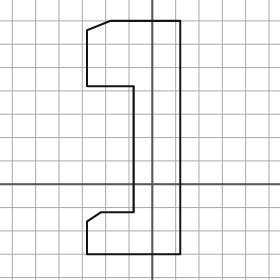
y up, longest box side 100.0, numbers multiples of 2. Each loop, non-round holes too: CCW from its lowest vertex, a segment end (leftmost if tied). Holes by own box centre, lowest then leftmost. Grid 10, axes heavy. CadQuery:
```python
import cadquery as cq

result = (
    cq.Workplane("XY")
    .moveTo(-28.0, -30.0)
    .lineTo(12.0, -30.0)
    .lineTo(12.0, 70.0)
    .lineTo(-18.0, 70.0)
    .lineTo(-28.0, 66.0)
    .lineTo(-28.0, 42.0)
    .lineTo(-8.0, 42.0)
    .lineTo(-8.0, -12.0)
    .lineTo(-22.0, -12.0)
    .lineTo(-28.0, -16.0)
    .close()
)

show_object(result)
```